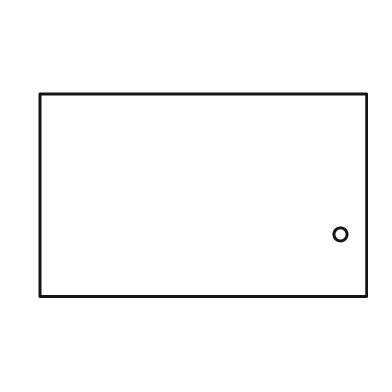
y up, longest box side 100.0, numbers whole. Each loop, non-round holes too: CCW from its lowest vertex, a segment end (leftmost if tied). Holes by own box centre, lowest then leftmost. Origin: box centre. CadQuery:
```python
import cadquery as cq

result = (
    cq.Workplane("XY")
    .moveTo(-50.0, -31.0)
    .lineTo(50.0, -31.0)
    .lineTo(50.0, 31.0)
    .lineTo(-50.0, 31.0)
    .close()
    .moveTo(42.0, -12.0)
    .circle(2.0)
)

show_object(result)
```